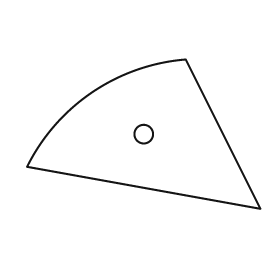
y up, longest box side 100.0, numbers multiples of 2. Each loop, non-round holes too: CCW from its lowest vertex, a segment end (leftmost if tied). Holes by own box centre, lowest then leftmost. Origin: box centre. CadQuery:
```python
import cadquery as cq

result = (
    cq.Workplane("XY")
    .moveTo(50.0, -32.0)
    .lineTo(18.0, 32.0)
    .threePointArc((-22.0, 18.0), (-50.0, -14.0))
    .close()
    .moveTo(0.0, 0.0)
    .circle(4.0)
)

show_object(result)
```